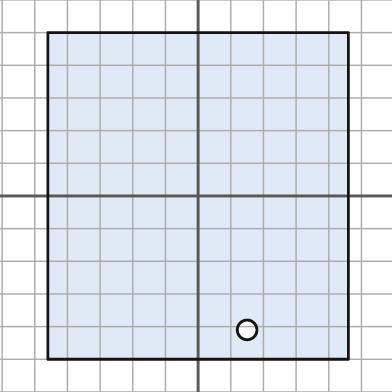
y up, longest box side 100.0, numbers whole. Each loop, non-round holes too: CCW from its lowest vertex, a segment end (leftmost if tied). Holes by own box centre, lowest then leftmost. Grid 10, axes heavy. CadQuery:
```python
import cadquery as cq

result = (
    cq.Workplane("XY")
    .moveTo(-46.0, -50.0)
    .lineTo(46.0, -50.0)
    .lineTo(46.0, 50.0)
    .lineTo(-46.0, 50.0)
    .close()
    .moveTo(15.0, -41.0)
    .circle(3.0)
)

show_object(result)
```